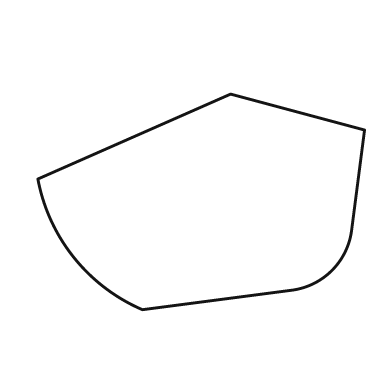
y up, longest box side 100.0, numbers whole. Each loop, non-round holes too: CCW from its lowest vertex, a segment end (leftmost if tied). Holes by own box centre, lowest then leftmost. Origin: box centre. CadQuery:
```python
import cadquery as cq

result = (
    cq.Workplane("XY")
    .moveTo(-18.0, -33.0)
    .lineTo(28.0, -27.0)
    .threePointArc((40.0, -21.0), (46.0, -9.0))
    .lineTo(50.0, 22.0)
    .lineTo(9.0, 33.0)
    .lineTo(-50.0, 7.0)
    .threePointArc((-39.0, -17.0), (-18.0, -33.0))
    .close()
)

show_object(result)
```